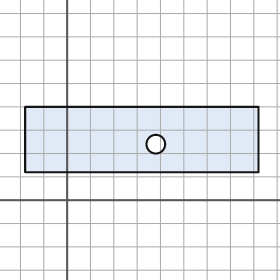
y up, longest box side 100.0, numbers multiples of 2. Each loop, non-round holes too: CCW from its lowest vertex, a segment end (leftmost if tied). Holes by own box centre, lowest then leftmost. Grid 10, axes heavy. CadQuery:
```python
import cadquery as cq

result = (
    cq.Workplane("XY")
    .moveTo(-18.0, 12.0)
    .lineTo(82.0, 12.0)
    .lineTo(82.0, 40.0)
    .lineTo(-18.0, 40.0)
    .close()
    .moveTo(38.0, 24.0)
    .circle(4.0)
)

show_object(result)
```